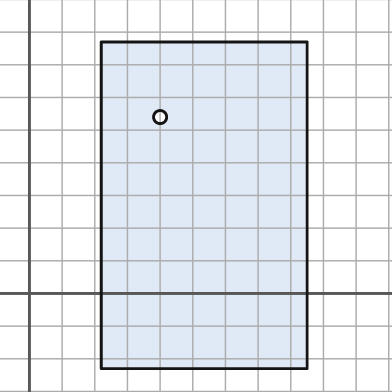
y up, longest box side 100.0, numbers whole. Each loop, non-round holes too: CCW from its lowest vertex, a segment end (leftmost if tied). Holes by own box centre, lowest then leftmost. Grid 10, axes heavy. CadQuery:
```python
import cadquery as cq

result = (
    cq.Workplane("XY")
    .moveTo(22.0, -23.0)
    .lineTo(85.0, -23.0)
    .lineTo(85.0, 77.0)
    .lineTo(22.0, 77.0)
    .close()
    .moveTo(40.0, 54.0)
    .circle(2.0)
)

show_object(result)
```